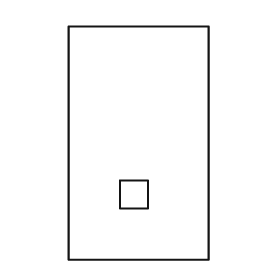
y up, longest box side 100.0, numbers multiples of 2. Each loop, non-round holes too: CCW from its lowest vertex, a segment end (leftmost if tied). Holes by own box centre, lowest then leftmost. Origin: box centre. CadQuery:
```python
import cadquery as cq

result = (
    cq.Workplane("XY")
    .moveTo(-30.0, -50.0)
    .lineTo(30.0, -50.0)
    .lineTo(30.0, 50.0)
    .lineTo(-30.0, 50.0)
    .close()
    .moveTo(-8.0, -28.0)
    .lineTo(4.0, -28.0)
    .lineTo(4.0, -16.0)
    .lineTo(-8.0, -16.0)
    .close()
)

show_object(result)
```